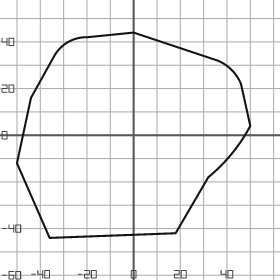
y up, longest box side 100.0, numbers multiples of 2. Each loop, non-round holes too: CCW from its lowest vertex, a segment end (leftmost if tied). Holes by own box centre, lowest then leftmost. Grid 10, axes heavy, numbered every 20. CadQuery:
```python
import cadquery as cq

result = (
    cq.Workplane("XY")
    .moveTo(-36.0, -44.0)
    .lineTo(18.0, -42.0)
    .lineTo(32.0, -18.0)
    .threePointArc((42.0, -8.0), (50.0, 4.0))
    .lineTo(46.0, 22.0)
    .threePointArc((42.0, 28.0), (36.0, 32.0))
    .lineTo(0.0, 44.0)
    .lineTo(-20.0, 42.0)
    .threePointArc((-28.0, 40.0), (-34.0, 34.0))
    .lineTo(-44.0, 16.0)
    .lineTo(-50.0, -12.0)
    .close()
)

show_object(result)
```